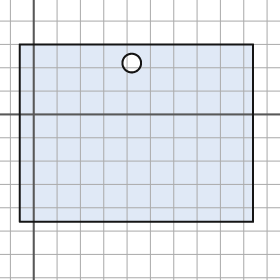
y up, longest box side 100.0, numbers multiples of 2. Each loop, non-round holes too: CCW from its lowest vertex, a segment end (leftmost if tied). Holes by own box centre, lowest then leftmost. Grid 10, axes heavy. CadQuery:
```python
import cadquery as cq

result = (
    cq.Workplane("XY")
    .moveTo(-6.0, -46.0)
    .lineTo(94.0, -46.0)
    .lineTo(94.0, 30.0)
    .lineTo(-6.0, 30.0)
    .close()
    .moveTo(42.0, 22.0)
    .circle(4.0)
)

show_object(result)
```